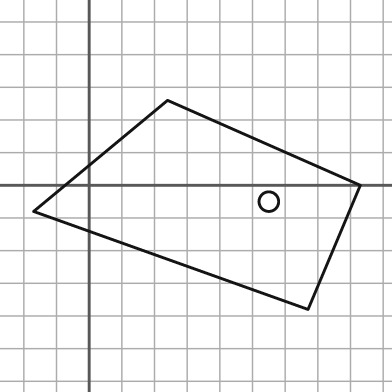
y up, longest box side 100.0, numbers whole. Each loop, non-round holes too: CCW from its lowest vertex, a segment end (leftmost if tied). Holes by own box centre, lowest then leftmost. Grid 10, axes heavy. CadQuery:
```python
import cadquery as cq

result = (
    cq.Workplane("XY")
    .moveTo(67.0, -38.0)
    .lineTo(83.0, 0.0)
    .lineTo(24.0, 26.0)
    .lineTo(-17.0, -8.0)
    .close()
    .moveTo(55.0, -5.0)
    .circle(3.0)
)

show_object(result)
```